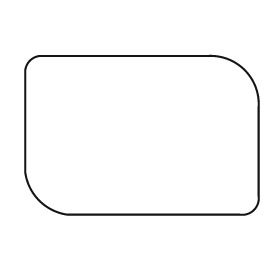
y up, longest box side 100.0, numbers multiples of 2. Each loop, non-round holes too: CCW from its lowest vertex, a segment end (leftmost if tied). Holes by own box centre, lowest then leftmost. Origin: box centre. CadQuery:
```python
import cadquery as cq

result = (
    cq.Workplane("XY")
    .moveTo(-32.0, -34.0)
    .lineTo(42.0, -34.0)
    .threePointArc((48.0, -32.0), (50.0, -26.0))
    .lineTo(50.0, 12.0)
    .threePointArc((44.0, 28.0), (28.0, 34.0))
    .lineTo(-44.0, 34.0)
    .threePointArc((-48.0, 32.0), (-50.0, 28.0))
    .lineTo(-50.0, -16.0)
    .threePointArc((-44.0, -28.0), (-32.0, -34.0))
    .close()
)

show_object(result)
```